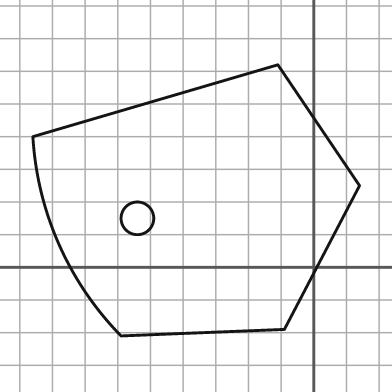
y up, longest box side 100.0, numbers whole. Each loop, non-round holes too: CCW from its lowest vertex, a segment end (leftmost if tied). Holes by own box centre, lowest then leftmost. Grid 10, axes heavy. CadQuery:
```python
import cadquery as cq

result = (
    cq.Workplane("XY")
    .moveTo(-59.0, -21.0)
    .lineTo(-9.0, -19.0)
    .lineTo(14.0, 25.0)
    .lineTo(-11.0, 62.0)
    .lineTo(-86.0, 40.0)
    .threePointArc((-78.0, 7.0), (-59.0, -21.0))
    .close()
    .moveTo(-54.0, 15.0)
    .circle(5.0)
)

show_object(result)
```